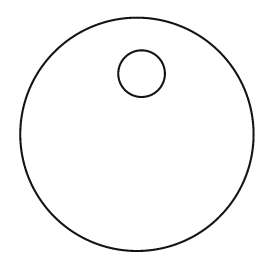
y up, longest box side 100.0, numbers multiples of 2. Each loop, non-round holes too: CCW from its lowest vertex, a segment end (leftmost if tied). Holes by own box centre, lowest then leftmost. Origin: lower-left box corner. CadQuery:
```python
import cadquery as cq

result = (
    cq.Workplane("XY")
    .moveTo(50.0, 50.0)
    .circle(50.0)
    .moveTo(52.0, 76.0)
    .circle(10.0)
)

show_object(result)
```